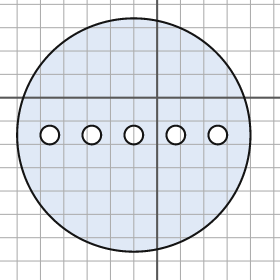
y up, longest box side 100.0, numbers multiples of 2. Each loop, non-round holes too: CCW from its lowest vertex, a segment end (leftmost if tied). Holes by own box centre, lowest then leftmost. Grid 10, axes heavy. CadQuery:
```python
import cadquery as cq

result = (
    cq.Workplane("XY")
    .moveTo(-10.0, -16.0)
    .circle(50.0)
    .moveTo(-46.0, -16.0)
    .circle(4.0)
    .moveTo(-28.0, -16.0)
    .circle(4.0)
    .moveTo(-10.0, -16.0)
    .circle(4.0)
    .moveTo(8.0, -16.0)
    .circle(4.0)
    .moveTo(26.0, -16.0)
    .circle(4.0)
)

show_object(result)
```